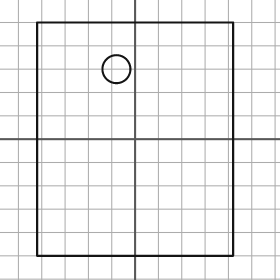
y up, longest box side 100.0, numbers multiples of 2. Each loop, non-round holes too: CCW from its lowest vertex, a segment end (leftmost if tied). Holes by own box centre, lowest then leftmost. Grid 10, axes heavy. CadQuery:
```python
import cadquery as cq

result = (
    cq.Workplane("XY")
    .moveTo(-42.0, -50.0)
    .lineTo(42.0, -50.0)
    .lineTo(42.0, 50.0)
    .lineTo(-42.0, 50.0)
    .close()
    .moveTo(-8.0, 30.0)
    .circle(6.0)
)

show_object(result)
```